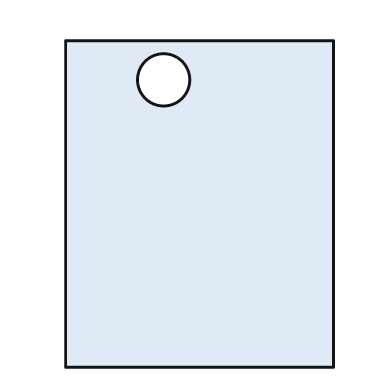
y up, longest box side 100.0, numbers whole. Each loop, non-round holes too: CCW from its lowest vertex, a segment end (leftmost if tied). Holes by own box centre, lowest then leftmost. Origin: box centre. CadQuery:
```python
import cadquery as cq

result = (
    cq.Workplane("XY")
    .moveTo(-41.0, -50.0)
    .lineTo(41.0, -50.0)
    .lineTo(41.0, 50.0)
    .lineTo(-41.0, 50.0)
    .close()
    .moveTo(-11.0, 38.0)
    .circle(8.0)
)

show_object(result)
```